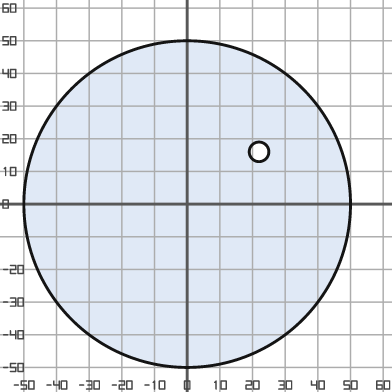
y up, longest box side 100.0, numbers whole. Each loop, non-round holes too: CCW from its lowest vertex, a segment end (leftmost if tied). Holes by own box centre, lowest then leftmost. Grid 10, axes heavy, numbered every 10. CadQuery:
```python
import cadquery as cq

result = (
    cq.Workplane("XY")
    .moveTo(0.0, 0.0)
    .circle(50.0)
    .moveTo(22.0, 16.0)
    .circle(3.0)
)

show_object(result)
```